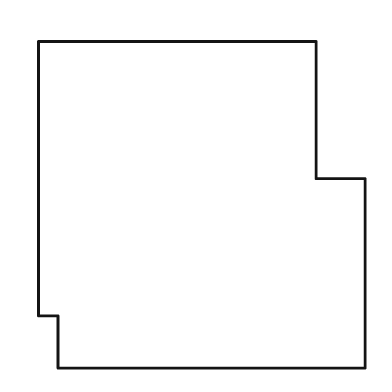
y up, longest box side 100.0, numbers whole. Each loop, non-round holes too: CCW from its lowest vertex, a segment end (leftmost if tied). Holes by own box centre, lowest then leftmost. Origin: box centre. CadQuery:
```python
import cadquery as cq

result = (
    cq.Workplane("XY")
    .moveTo(-44.0, -50.0)
    .lineTo(50.0, -50.0)
    .lineTo(50.0, 8.0)
    .lineTo(35.0, 8.0)
    .lineTo(35.0, 50.0)
    .lineTo(-50.0, 50.0)
    .lineTo(-50.0, -34.0)
    .lineTo(-44.0, -34.0)
    .close()
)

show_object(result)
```